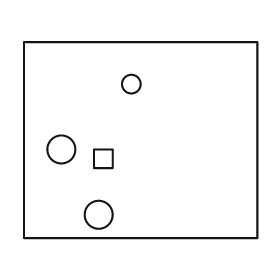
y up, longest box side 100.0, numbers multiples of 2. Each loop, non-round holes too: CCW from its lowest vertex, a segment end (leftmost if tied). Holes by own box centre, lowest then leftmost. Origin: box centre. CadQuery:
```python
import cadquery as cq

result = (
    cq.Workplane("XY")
    .moveTo(-50.0, -42.0)
    .lineTo(50.0, -42.0)
    .lineTo(50.0, 42.0)
    .lineTo(-50.0, 42.0)
    .close()
    .moveTo(-18.0, -32.0)
    .circle(6.0)
    .moveTo(-20.0, -12.0)
    .lineTo(-12.0, -12.0)
    .lineTo(-12.0, -4.0)
    .lineTo(-20.0, -4.0)
    .close()
    .moveTo(-34.0, -4.0)
    .circle(6.0)
    .moveTo(-4.0, 24.0)
    .circle(4.0)
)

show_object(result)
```